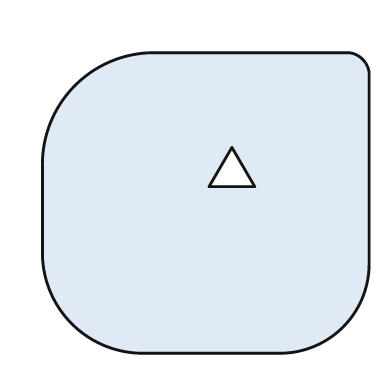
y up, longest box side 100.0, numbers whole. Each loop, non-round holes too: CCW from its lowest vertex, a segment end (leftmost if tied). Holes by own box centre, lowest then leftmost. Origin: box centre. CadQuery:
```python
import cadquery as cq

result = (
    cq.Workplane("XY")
    .moveTo(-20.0, -46.0)
    .lineTo(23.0, -46.0)
    .threePointArc((42.0, -38.0), (50.0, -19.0))
    .lineTo(50.0, 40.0)
    .threePointArc((48.0, 44.0), (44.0, 46.0))
    .lineTo(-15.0, 46.0)
    .threePointArc((-40.0, 36.0), (-50.0, 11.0))
    .lineTo(-50.0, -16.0)
    .threePointArc((-41.0, -37.0), (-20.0, -46.0))
    .close()
    .moveTo(1.0, 5.0)
    .lineTo(15.0, 5.0)
    .lineTo(8.0, 17.0)
    .close()
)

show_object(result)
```